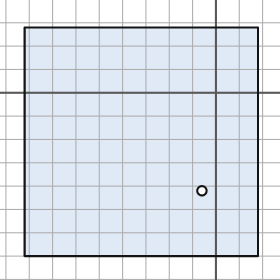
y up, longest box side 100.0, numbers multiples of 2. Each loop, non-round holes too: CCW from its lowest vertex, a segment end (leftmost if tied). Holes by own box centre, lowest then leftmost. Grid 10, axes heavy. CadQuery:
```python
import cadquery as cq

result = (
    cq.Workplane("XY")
    .moveTo(-82.0, -70.0)
    .lineTo(18.0, -70.0)
    .lineTo(18.0, 28.0)
    .lineTo(-82.0, 28.0)
    .close()
    .moveTo(-6.0, -42.0)
    .circle(2.0)
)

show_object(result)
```